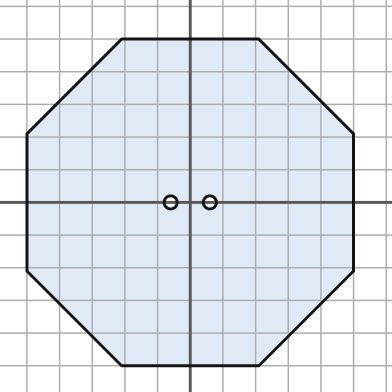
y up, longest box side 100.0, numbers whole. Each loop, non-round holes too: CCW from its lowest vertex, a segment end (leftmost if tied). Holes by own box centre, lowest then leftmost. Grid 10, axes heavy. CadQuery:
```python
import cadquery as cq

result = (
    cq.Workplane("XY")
    .moveTo(-21.0, -50.0)
    .lineTo(21.0, -50.0)
    .lineTo(50.0, -21.0)
    .lineTo(50.0, 21.0)
    .lineTo(21.0, 50.0)
    .lineTo(-21.0, 50.0)
    .lineTo(-50.0, 21.0)
    .lineTo(-50.0, -21.0)
    .close()
    .moveTo(-6.0, 0.0)
    .circle(2.0)
    .moveTo(6.0, 0.0)
    .circle(2.0)
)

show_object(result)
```